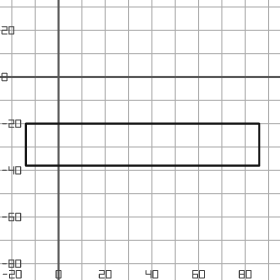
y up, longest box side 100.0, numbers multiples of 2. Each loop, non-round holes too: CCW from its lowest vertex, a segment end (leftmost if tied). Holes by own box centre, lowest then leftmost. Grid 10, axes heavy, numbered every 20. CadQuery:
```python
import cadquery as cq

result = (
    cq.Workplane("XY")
    .moveTo(-14.0, -38.0)
    .lineTo(86.0, -38.0)
    .lineTo(86.0, -20.0)
    .lineTo(-14.0, -20.0)
    .close()
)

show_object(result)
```